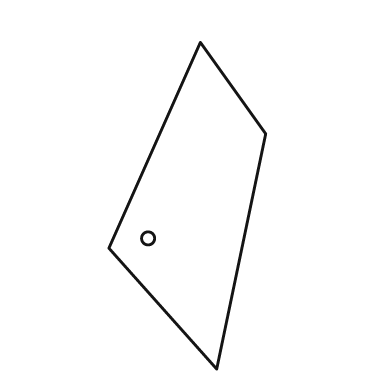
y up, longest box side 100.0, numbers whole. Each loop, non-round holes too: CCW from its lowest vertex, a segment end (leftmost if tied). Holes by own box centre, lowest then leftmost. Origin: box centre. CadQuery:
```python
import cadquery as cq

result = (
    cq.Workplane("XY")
    .moveTo(9.0, -50.0)
    .lineTo(24.0, 22.0)
    .lineTo(4.0, 50.0)
    .lineTo(-24.0, -13.0)
    .close()
    .moveTo(-12.0, -10.0)
    .circle(2.0)
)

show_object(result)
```